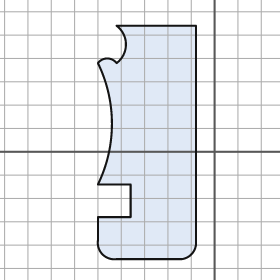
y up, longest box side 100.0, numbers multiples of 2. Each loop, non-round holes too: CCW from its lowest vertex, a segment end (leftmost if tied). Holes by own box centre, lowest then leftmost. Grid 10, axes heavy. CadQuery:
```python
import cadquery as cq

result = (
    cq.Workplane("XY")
    .moveTo(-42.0, -46.0)
    .lineTo(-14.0, -46.0)
    .threePointArc((-10.0, -44.0), (-8.0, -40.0))
    .lineTo(-8.0, 54.0)
    .lineTo(-42.0, 54.0)
    .threePointArc((-38.0, 46.0), (-42.0, 38.0))
    .threePointArc((-46.0, 40.0), (-50.0, 38.0))
    .threePointArc((-44.0, 12.0), (-50.0, -14.0))
    .lineTo(-36.0, -14.0)
    .lineTo(-36.0, -28.0)
    .lineTo(-50.0, -28.0)
    .lineTo(-50.0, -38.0)
    .threePointArc((-48.0, -44.0), (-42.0, -46.0))
    .close()
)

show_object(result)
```